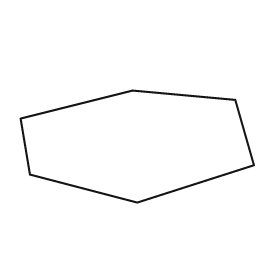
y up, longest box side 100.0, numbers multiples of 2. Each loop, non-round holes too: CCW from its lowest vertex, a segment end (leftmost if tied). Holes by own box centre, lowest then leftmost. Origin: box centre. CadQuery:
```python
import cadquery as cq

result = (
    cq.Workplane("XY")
    .moveTo(0.0, -24.0)
    .lineTo(50.0, -8.0)
    .lineTo(42.0, 20.0)
    .lineTo(-2.0, 24.0)
    .lineTo(-50.0, 12.0)
    .lineTo(-46.0, -12.0)
    .close()
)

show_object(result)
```